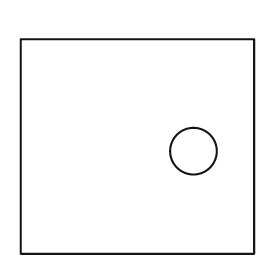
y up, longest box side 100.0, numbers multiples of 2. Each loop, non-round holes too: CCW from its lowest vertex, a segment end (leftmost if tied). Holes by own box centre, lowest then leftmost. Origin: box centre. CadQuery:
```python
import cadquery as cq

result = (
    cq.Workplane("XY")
    .moveTo(-50.0, -46.0)
    .lineTo(50.0, -46.0)
    .lineTo(50.0, 46.0)
    .lineTo(-50.0, 46.0)
    .close()
    .moveTo(24.0, -2.0)
    .circle(10.0)
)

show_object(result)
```